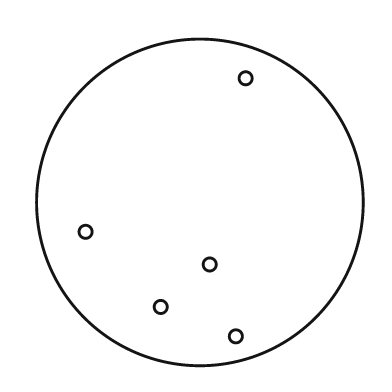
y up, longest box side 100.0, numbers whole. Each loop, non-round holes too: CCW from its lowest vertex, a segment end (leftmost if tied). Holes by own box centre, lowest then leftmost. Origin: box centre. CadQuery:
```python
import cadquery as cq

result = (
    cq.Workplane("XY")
    .moveTo(0.0, 0.0)
    .circle(50.0)
    .moveTo(11.0, -41.0)
    .circle(2.0)
    .moveTo(-12.0, -32.0)
    .circle(2.0)
    .moveTo(3.0, -19.0)
    .circle(2.0)
    .moveTo(-35.0, -9.0)
    .circle(2.0)
    .moveTo(14.0, 38.0)
    .circle(2.0)
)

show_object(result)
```